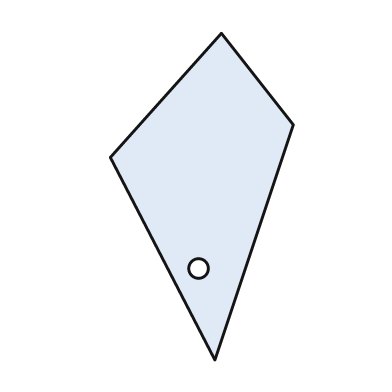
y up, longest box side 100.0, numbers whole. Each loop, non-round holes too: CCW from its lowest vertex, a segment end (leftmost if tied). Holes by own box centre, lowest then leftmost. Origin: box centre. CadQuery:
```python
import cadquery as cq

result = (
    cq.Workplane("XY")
    .moveTo(4.0, -50.0)
    .lineTo(28.0, 22.0)
    .lineTo(6.0, 50.0)
    .lineTo(-28.0, 12.0)
    .close()
    .moveTo(-1.0, -22.0)
    .circle(3.0)
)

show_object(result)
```